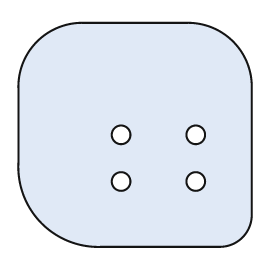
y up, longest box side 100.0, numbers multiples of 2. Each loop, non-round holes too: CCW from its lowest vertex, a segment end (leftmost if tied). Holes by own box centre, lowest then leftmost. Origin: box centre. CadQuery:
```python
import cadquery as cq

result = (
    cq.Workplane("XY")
    .moveTo(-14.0, -48.0)
    .lineTo(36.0, -48.0)
    .threePointArc((46.0, -44.0), (50.0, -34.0))
    .lineTo(50.0, 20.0)
    .threePointArc((42.0, 40.0), (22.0, 48.0))
    .lineTo(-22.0, 48.0)
    .threePointArc((-42.0, 40.0), (-50.0, 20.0))
    .lineTo(-50.0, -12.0)
    .threePointArc((-40.0, -38.0), (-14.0, -48.0))
    .close()
    .moveTo(-6.0, -20.0)
    .circle(4.0)
    .moveTo(26.0, -20.0)
    .circle(4.0)
    .moveTo(-6.0, 0.0)
    .circle(4.0)
    .moveTo(26.0, 0.0)
    .circle(4.0)
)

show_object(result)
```